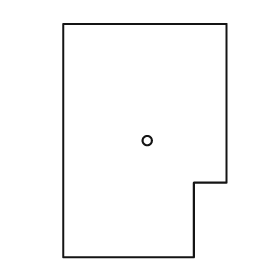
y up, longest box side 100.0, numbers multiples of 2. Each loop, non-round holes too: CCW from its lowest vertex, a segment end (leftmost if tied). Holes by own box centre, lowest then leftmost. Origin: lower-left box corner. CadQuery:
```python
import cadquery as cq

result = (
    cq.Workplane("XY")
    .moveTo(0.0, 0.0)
    .lineTo(56.0, 0.0)
    .lineTo(56.0, 32.0)
    .lineTo(70.0, 32.0)
    .lineTo(70.0, 100.0)
    .lineTo(0.0, 100.0)
    .close()
    .moveTo(36.0, 50.0)
    .circle(2.0)
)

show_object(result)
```